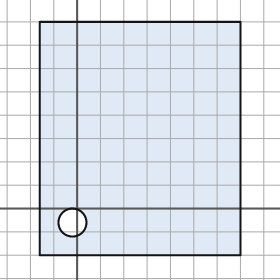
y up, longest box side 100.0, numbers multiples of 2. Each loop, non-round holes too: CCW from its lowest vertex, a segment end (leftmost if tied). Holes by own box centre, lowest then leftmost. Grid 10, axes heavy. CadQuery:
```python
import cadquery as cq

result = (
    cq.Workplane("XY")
    .moveTo(-16.0, -20.0)
    .lineTo(70.0, -20.0)
    .lineTo(70.0, 80.0)
    .lineTo(-16.0, 80.0)
    .close()
    .moveTo(-2.0, -6.0)
    .circle(6.0)
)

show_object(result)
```